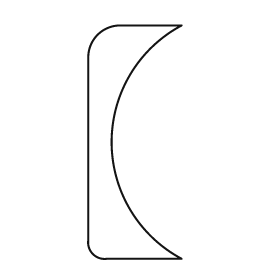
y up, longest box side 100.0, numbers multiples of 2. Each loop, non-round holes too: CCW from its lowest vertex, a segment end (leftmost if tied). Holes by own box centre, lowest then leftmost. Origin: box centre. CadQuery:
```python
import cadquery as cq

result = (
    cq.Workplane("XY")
    .moveTo(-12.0, -50.0)
    .lineTo(20.0, -50.0)
    .threePointArc((-10.0, 0.0), (20.0, 50.0))
    .lineTo(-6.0, 50.0)
    .threePointArc((-16.0, 46.0), (-20.0, 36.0))
    .lineTo(-20.0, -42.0)
    .threePointArc((-18.0, -48.0), (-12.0, -50.0))
    .close()
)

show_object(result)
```